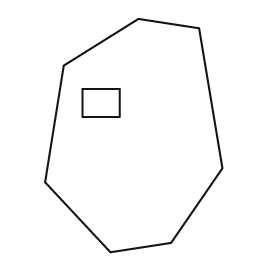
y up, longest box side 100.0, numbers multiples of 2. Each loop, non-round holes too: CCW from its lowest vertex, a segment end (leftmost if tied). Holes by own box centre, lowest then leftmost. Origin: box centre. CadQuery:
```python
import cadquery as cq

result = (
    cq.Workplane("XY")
    .moveTo(-10.0, -50.0)
    .lineTo(16.0, -46.0)
    .lineTo(38.0, -14.0)
    .lineTo(28.0, 46.0)
    .lineTo(2.0, 50.0)
    .lineTo(-30.0, 30.0)
    .lineTo(-38.0, -20.0)
    .close()
    .moveTo(-22.0, 8.0)
    .lineTo(-6.0, 8.0)
    .lineTo(-6.0, 20.0)
    .lineTo(-22.0, 20.0)
    .close()
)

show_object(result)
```